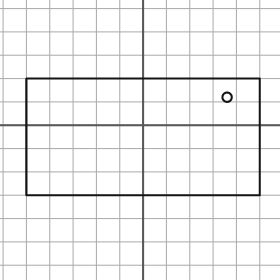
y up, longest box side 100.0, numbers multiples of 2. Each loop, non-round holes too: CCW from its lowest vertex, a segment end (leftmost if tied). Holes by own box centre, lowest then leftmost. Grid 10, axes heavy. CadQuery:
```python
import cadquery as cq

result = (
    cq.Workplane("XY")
    .moveTo(-50.0, -30.0)
    .lineTo(50.0, -30.0)
    .lineTo(50.0, 20.0)
    .lineTo(-50.0, 20.0)
    .close()
    .moveTo(36.0, 12.0)
    .circle(2.0)
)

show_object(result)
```